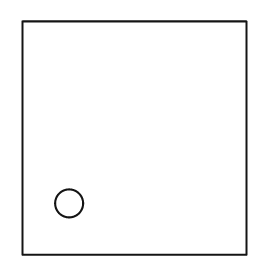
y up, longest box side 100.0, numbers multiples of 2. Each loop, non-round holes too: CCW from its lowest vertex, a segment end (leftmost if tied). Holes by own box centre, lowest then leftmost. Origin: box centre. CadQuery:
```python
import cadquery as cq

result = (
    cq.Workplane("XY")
    .moveTo(-48.0, -50.0)
    .lineTo(48.0, -50.0)
    .lineTo(48.0, 50.0)
    .lineTo(-48.0, 50.0)
    .close()
    .moveTo(-28.0, -28.0)
    .circle(6.0)
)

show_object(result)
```